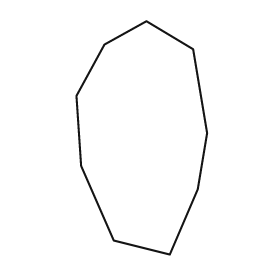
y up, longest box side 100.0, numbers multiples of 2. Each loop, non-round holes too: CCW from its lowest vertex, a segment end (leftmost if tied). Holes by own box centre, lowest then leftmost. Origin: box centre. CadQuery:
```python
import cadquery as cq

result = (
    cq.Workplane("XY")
    .moveTo(12.0, -50.0)
    .lineTo(24.0, -22.0)
    .lineTo(28.0, 2.0)
    .lineTo(22.0, 38.0)
    .lineTo(2.0, 50.0)
    .lineTo(-16.0, 40.0)
    .lineTo(-28.0, 18.0)
    .lineTo(-26.0, -12.0)
    .lineTo(-12.0, -44.0)
    .close()
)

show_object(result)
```